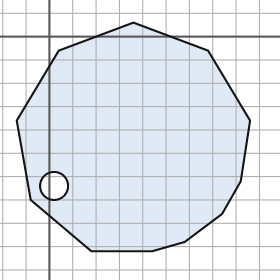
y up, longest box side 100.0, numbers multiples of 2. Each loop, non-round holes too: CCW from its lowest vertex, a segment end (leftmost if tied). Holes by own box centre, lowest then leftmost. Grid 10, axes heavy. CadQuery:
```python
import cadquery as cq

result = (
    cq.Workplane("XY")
    .moveTo(18.0, -92.0)
    .lineTo(44.0, -92.0)
    .lineTo(58.0, -88.0)
    .lineTo(74.0, -76.0)
    .lineTo(82.0, -62.0)
    .lineTo(86.0, -36.0)
    .lineTo(68.0, -6.0)
    .lineTo(36.0, 6.0)
    .lineTo(4.0, -6.0)
    .lineTo(-14.0, -36.0)
    .lineTo(-8.0, -70.0)
    .close()
    .moveTo(2.0, -64.0)
    .circle(6.0)
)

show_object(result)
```